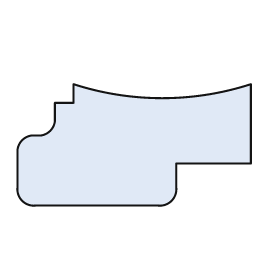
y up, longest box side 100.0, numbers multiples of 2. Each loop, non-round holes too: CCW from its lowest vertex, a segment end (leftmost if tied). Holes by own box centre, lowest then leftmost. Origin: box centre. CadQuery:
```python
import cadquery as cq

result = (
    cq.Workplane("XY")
    .moveTo(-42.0, -26.0)
    .lineTo(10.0, -26.0)
    .threePointArc((16.0, -24.0), (18.0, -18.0))
    .lineTo(18.0, -8.0)
    .lineTo(50.0, -8.0)
    .lineTo(50.0, 26.0)
    .threePointArc((12.0, 20.0), (-26.0, 26.0))
    .lineTo(-26.0, 18.0)
    .lineTo(-34.0, 18.0)
    .lineTo(-34.0, 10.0)
    .threePointArc((-36.0, 6.0), (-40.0, 4.0))
    .lineTo(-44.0, 4.0)
    .threePointArc((-48.0, 2.0), (-50.0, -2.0))
    .lineTo(-50.0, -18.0)
    .threePointArc((-48.0, -24.0), (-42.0, -26.0))
    .close()
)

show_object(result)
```